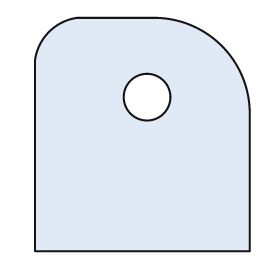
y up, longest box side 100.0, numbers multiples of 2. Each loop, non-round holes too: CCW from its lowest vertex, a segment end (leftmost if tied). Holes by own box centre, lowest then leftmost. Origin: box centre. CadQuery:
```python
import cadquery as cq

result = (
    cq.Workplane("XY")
    .moveTo(-46.0, -50.0)
    .lineTo(46.0, -50.0)
    .lineTo(46.0, 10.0)
    .threePointArc((34.0, 38.0), (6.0, 50.0))
    .lineTo(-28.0, 50.0)
    .threePointArc((-40.0, 44.0), (-46.0, 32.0))
    .close()
    .moveTo(2.0, 16.0)
    .circle(10.0)
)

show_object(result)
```